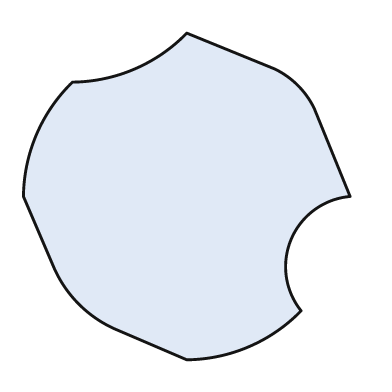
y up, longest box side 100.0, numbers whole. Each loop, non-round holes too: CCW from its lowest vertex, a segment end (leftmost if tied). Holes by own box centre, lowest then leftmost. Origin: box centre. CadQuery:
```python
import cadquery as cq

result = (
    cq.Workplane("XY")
    .moveTo(0.0, -50.0)
    .threePointArc((19.0, -46.0), (35.0, -35.0))
    .threePointArc((32.0, -13.0), (50.0, 0.0))
    .lineTo(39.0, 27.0)
    .threePointArc((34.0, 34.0), (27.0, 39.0))
    .lineTo(0.0, 50.0)
    .threePointArc((-16.0, 39.0), (-35.0, 35.0))
    .threePointArc((-46.0, 19.0), (-50.0, 0.0))
    .lineTo(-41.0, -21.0)
    .threePointArc((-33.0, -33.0), (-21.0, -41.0))
    .close()
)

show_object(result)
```